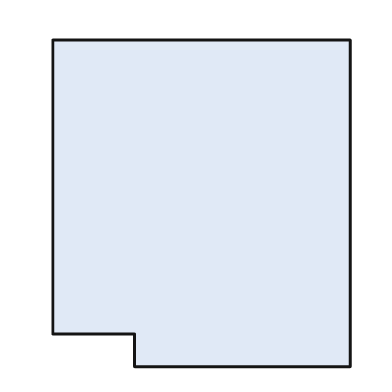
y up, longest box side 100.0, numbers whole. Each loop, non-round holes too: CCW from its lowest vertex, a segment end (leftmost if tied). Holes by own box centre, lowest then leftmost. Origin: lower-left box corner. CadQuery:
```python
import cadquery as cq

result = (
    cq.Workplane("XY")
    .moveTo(25.0, 0.0)
    .lineTo(91.0, 0.0)
    .lineTo(91.0, 100.0)
    .lineTo(0.0, 100.0)
    .lineTo(0.0, 10.0)
    .lineTo(25.0, 10.0)
    .close()
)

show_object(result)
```